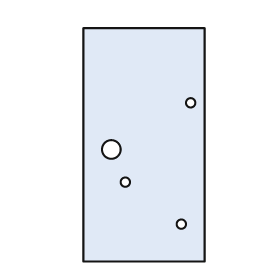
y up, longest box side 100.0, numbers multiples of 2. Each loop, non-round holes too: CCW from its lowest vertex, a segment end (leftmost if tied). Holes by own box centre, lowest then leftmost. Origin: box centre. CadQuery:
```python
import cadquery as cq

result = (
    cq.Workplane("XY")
    .moveTo(-26.0, -50.0)
    .lineTo(26.0, -50.0)
    .lineTo(26.0, 50.0)
    .lineTo(-26.0, 50.0)
    .close()
    .moveTo(16.0, -34.0)
    .circle(2.0)
    .moveTo(-8.0, -16.0)
    .circle(2.0)
    .moveTo(-14.0, -2.0)
    .circle(4.0)
    .moveTo(20.0, 18.0)
    .circle(2.0)
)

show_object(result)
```